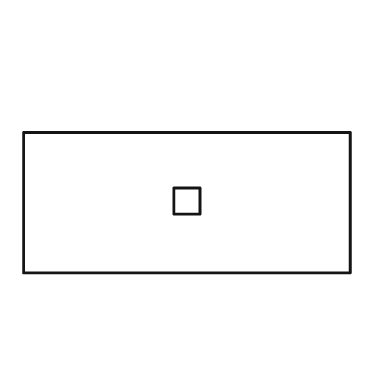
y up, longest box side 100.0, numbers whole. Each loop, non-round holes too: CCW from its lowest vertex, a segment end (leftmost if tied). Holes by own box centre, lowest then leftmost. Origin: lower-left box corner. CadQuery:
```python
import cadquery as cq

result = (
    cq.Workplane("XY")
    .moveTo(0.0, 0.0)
    .lineTo(100.0, 0.0)
    .lineTo(100.0, 43.0)
    .lineTo(0.0, 43.0)
    .close()
    .moveTo(46.0, 18.0)
    .lineTo(54.0, 18.0)
    .lineTo(54.0, 26.0)
    .lineTo(46.0, 26.0)
    .close()
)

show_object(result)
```